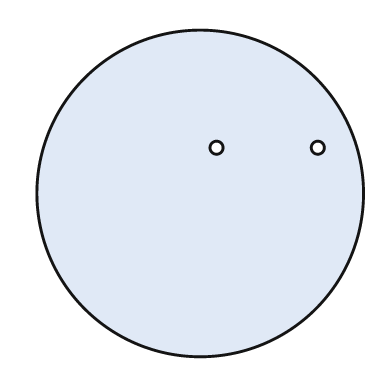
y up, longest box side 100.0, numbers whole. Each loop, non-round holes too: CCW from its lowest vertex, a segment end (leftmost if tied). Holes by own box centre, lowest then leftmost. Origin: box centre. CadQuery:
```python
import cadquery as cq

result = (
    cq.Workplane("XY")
    .moveTo(0.0, 0.0)
    .circle(50.0)
    .moveTo(5.0, 14.0)
    .circle(2.0)
    .moveTo(36.0, 14.0)
    .circle(2.0)
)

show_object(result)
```